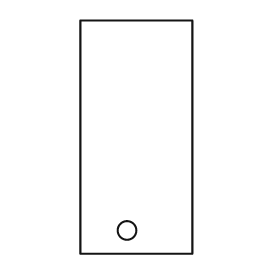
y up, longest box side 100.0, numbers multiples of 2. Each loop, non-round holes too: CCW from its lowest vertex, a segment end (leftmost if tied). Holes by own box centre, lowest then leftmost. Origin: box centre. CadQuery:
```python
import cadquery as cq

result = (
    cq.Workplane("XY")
    .moveTo(-24.0, -50.0)
    .lineTo(24.0, -50.0)
    .lineTo(24.0, 50.0)
    .lineTo(-24.0, 50.0)
    .close()
    .moveTo(-4.0, -40.0)
    .circle(4.0)
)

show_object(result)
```